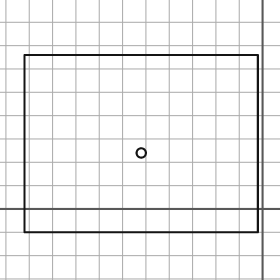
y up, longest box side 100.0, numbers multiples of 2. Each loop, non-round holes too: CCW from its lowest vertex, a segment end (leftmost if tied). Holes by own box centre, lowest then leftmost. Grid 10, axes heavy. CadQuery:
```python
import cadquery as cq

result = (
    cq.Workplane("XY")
    .moveTo(-102.0, -10.0)
    .lineTo(-2.0, -10.0)
    .lineTo(-2.0, 66.0)
    .lineTo(-102.0, 66.0)
    .close()
    .moveTo(-52.0, 24.0)
    .circle(2.0)
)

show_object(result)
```